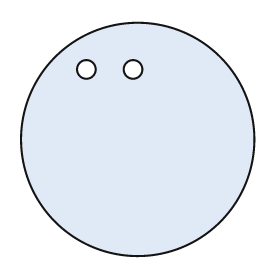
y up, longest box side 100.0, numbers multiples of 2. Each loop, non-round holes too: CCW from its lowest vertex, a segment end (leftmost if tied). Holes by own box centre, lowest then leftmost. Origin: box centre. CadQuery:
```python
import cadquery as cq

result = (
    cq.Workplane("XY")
    .moveTo(0.0, 0.0)
    .circle(50.0)
    .moveTo(-22.0, 30.0)
    .circle(4.0)
    .moveTo(-2.0, 30.0)
    .circle(4.0)
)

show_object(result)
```